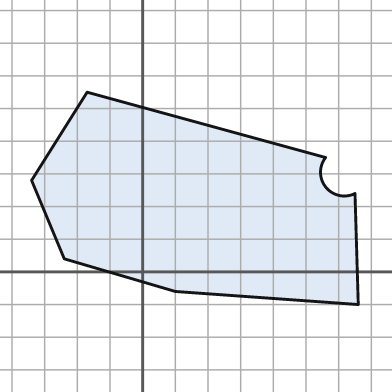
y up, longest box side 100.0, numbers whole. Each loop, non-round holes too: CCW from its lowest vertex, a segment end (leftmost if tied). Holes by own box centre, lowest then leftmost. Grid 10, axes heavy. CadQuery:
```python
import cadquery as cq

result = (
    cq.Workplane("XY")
    .moveTo(66.0, -10.0)
    .lineTo(65.0, 24.0)
    .threePointArc((56.0, 26.0), (56.0, 35.0))
    .lineTo(-17.0, 55.0)
    .lineTo(-34.0, 28.0)
    .lineTo(-24.0, 4.0)
    .lineTo(10.0, -6.0)
    .close()
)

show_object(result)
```